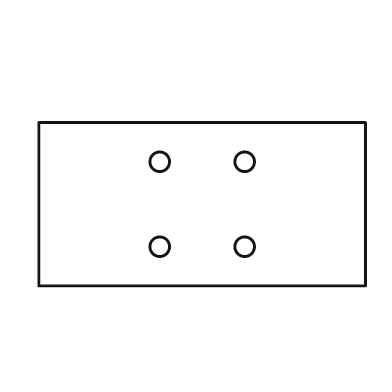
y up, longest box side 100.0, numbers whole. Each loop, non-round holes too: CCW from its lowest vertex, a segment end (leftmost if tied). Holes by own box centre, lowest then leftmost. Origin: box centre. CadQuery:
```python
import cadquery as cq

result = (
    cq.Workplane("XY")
    .moveTo(-50.0, -25.0)
    .lineTo(50.0, -25.0)
    .lineTo(50.0, 25.0)
    .lineTo(-50.0, 25.0)
    .close()
    .moveTo(-13.0, -13.0)
    .circle(3.0)
    .moveTo(13.0, -13.0)
    .circle(3.0)
    .moveTo(-13.0, 13.0)
    .circle(3.0)
    .moveTo(13.0, 13.0)
    .circle(3.0)
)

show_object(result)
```